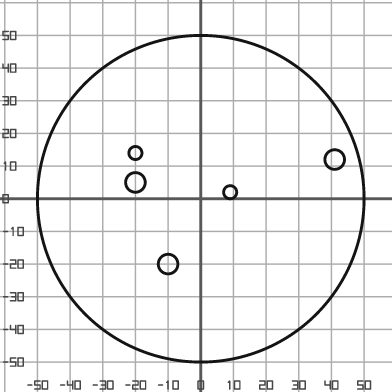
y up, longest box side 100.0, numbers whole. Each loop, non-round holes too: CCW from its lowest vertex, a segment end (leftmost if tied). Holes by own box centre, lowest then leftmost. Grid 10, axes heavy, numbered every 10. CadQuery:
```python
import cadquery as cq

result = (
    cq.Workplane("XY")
    .moveTo(0.0, 0.0)
    .circle(50.0)
    .moveTo(-10.0, -20.0)
    .circle(3.0)
    .moveTo(9.0, 2.0)
    .circle(2.0)
    .moveTo(-20.0, 5.0)
    .circle(3.0)
    .moveTo(41.0, 12.0)
    .circle(3.0)
    .moveTo(-20.0, 14.0)
    .circle(2.0)
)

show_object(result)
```